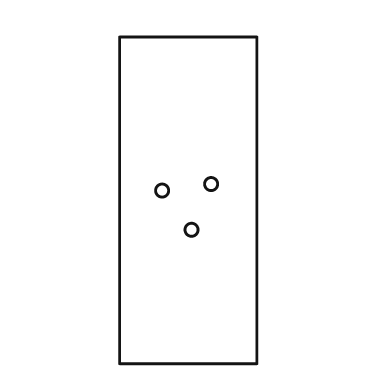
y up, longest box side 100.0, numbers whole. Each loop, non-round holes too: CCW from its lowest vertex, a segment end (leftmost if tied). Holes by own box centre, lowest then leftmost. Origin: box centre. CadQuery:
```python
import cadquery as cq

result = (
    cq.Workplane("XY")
    .moveTo(-21.0, -50.0)
    .lineTo(21.0, -50.0)
    .lineTo(21.0, 50.0)
    .lineTo(-21.0, 50.0)
    .close()
    .moveTo(1.0, -9.0)
    .circle(2.0)
    .moveTo(-8.0, 3.0)
    .circle(2.0)
    .moveTo(7.0, 5.0)
    .circle(2.0)
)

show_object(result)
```